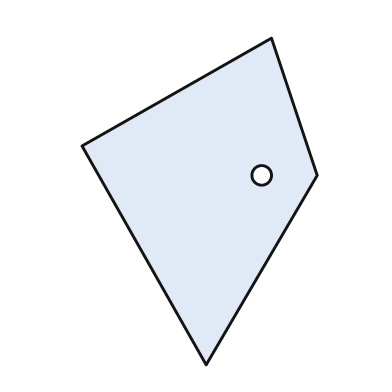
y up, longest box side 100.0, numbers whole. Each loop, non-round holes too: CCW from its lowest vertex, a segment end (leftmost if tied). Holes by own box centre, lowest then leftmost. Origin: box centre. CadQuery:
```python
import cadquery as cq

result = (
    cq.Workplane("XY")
    .moveTo(2.0, -50.0)
    .lineTo(36.0, 8.0)
    .lineTo(22.0, 50.0)
    .lineTo(-36.0, 17.0)
    .close()
    .moveTo(19.0, 8.0)
    .circle(3.0)
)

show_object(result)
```